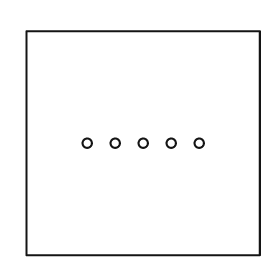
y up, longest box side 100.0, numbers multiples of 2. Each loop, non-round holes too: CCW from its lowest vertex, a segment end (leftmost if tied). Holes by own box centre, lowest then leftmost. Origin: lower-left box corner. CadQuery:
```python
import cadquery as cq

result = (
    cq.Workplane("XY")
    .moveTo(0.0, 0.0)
    .lineTo(100.0, 0.0)
    .lineTo(100.0, 96.0)
    .lineTo(0.0, 96.0)
    .close()
    .moveTo(26.0, 48.0)
    .circle(2.0)
    .moveTo(38.0, 48.0)
    .circle(2.0)
    .moveTo(50.0, 48.0)
    .circle(2.0)
    .moveTo(62.0, 48.0)
    .circle(2.0)
    .moveTo(74.0, 48.0)
    .circle(2.0)
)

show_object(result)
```